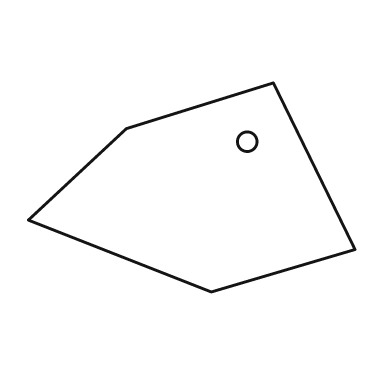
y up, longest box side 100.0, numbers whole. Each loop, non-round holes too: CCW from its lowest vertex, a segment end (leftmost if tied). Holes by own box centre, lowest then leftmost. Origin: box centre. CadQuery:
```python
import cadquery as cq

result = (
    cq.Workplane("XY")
    .moveTo(6.0, -32.0)
    .lineTo(50.0, -19.0)
    .lineTo(25.0, 32.0)
    .lineTo(-20.0, 18.0)
    .lineTo(-50.0, -10.0)
    .close()
    .moveTo(17.0, 14.0)
    .circle(3.0)
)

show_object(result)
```